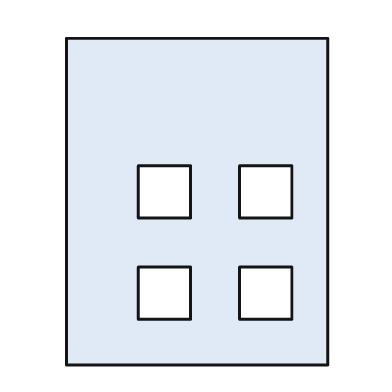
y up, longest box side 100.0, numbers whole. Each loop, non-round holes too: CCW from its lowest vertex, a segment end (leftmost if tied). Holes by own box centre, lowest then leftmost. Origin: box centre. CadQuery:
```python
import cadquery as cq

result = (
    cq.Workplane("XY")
    .moveTo(-40.0, -50.0)
    .lineTo(40.0, -50.0)
    .lineTo(40.0, 50.0)
    .lineTo(-40.0, 50.0)
    .close()
    .moveTo(-18.0, -36.0)
    .lineTo(-2.0, -36.0)
    .lineTo(-2.0, -20.0)
    .lineTo(-18.0, -20.0)
    .close()
    .moveTo(13.0, -36.0)
    .lineTo(29.0, -36.0)
    .lineTo(29.0, -20.0)
    .lineTo(13.0, -20.0)
    .close()
    .moveTo(-18.0, -5.0)
    .lineTo(-2.0, -5.0)
    .lineTo(-2.0, 11.0)
    .lineTo(-18.0, 11.0)
    .close()
    .moveTo(13.0, -5.0)
    .lineTo(29.0, -5.0)
    .lineTo(29.0, 11.0)
    .lineTo(13.0, 11.0)
    .close()
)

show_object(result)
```